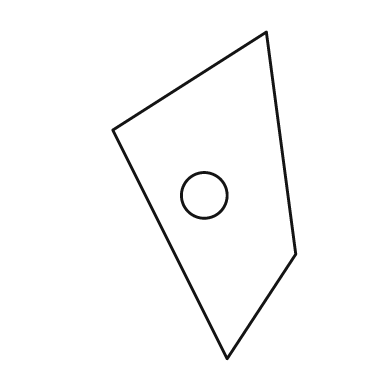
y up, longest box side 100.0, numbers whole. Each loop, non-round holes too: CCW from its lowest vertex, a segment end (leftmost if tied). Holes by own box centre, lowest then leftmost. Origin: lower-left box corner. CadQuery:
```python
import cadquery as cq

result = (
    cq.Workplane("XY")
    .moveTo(35.0, 0.0)
    .lineTo(56.0, 32.0)
    .lineTo(47.0, 100.0)
    .lineTo(0.0, 70.0)
    .close()
    .moveTo(28.0, 50.0)
    .circle(7.0)
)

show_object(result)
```